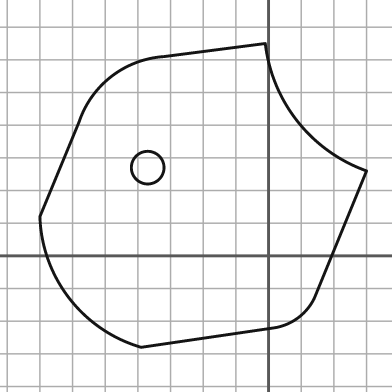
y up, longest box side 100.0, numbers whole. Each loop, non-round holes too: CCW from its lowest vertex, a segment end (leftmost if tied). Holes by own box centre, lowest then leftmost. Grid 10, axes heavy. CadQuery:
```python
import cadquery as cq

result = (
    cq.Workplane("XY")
    .moveTo(-39.0, -28.0)
    .lineTo(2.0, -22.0)
    .threePointArc((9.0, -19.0), (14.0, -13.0))
    .lineTo(30.0, 26.0)
    .threePointArc((9.0, 41.0), (-1.0, 65.0))
    .lineTo(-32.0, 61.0)
    .threePointArc((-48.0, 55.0), (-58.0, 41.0))
    .lineTo(-70.0, 12.0)
    .threePointArc((-61.0, -13.0), (-39.0, -28.0))
    .close()
    .moveTo(-37.0, 27.0)
    .circle(5.0)
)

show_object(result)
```